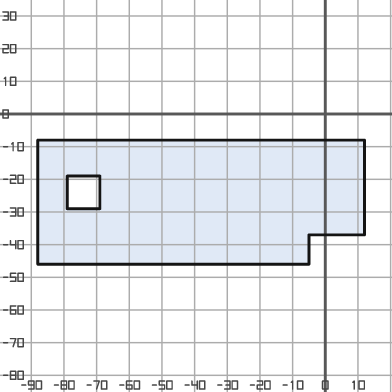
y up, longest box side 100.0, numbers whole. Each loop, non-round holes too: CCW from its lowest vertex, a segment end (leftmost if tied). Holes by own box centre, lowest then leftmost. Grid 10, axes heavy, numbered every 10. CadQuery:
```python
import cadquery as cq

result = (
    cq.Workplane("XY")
    .moveTo(-88.0, -46.0)
    .lineTo(-5.0, -46.0)
    .lineTo(-5.0, -37.0)
    .lineTo(12.0, -37.0)
    .lineTo(12.0, -8.0)
    .lineTo(-88.0, -8.0)
    .close()
    .moveTo(-79.0, -29.0)
    .lineTo(-69.0, -29.0)
    .lineTo(-69.0, -19.0)
    .lineTo(-79.0, -19.0)
    .close()
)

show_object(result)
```